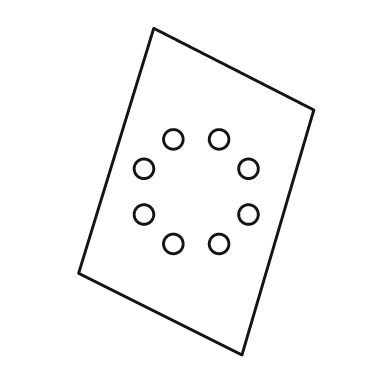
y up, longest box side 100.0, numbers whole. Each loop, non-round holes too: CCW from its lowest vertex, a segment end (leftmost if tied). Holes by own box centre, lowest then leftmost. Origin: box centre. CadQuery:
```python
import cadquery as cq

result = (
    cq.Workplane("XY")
    .moveTo(14.0, -50.0)
    .lineTo(36.0, 25.0)
    .lineTo(-13.0, 50.0)
    .lineTo(-36.0, -25.0)
    .close()
    .moveTo(-7.0, -16.0)
    .circle(3.0)
    .moveTo(7.0, -16.0)
    .circle(3.0)
    .moveTo(-16.0, -7.0)
    .circle(3.0)
    .moveTo(16.0, -7.0)
    .circle(3.0)
    .moveTo(-16.0, 7.0)
    .circle(3.0)
    .moveTo(16.0, 7.0)
    .circle(3.0)
    .moveTo(-7.0, 16.0)
    .circle(3.0)
    .moveTo(7.0, 16.0)
    .circle(3.0)
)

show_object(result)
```